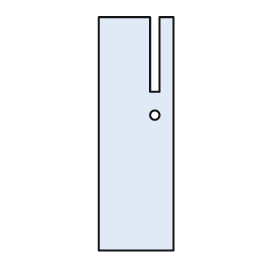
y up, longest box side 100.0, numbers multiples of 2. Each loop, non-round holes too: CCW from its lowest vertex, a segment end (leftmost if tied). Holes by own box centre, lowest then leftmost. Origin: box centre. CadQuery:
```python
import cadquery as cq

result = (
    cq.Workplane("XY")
    .moveTo(-16.0, -50.0)
    .lineTo(16.0, -50.0)
    .lineTo(16.0, 50.0)
    .lineTo(10.0, 50.0)
    .lineTo(10.0, 18.0)
    .lineTo(6.0, 18.0)
    .lineTo(6.0, 50.0)
    .lineTo(-16.0, 50.0)
    .close()
    .moveTo(8.0, 8.0)
    .circle(2.0)
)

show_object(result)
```